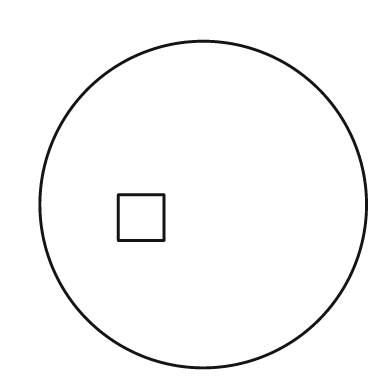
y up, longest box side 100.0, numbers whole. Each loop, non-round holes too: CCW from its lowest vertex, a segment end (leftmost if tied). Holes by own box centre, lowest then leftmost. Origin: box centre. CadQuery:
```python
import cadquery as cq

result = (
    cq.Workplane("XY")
    .moveTo(0.0, 0.0)
    .circle(50.0)
    .moveTo(-26.0, -11.0)
    .lineTo(-12.0, -11.0)
    .lineTo(-12.0, 3.0)
    .lineTo(-26.0, 3.0)
    .close()
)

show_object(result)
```